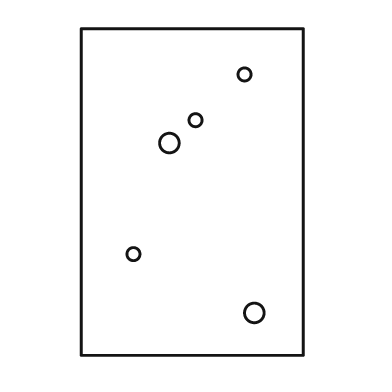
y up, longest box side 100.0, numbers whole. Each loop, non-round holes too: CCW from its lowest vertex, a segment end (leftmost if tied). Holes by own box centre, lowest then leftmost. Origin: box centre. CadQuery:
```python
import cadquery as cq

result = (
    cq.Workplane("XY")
    .moveTo(-34.0, -50.0)
    .lineTo(34.0, -50.0)
    .lineTo(34.0, 50.0)
    .lineTo(-34.0, 50.0)
    .close()
    .moveTo(19.0, -37.0)
    .circle(3.0)
    .moveTo(-18.0, -19.0)
    .circle(2.0)
    .moveTo(-7.0, 15.0)
    .circle(3.0)
    .moveTo(1.0, 22.0)
    .circle(2.0)
    .moveTo(16.0, 36.0)
    .circle(2.0)
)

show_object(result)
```